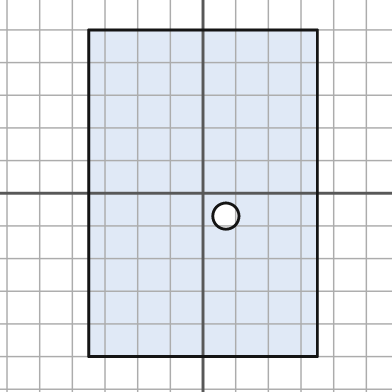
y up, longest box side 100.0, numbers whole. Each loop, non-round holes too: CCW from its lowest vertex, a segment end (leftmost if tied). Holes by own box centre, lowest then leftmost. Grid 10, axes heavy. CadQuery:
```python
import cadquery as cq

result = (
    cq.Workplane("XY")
    .moveTo(-35.0, -50.0)
    .lineTo(35.0, -50.0)
    .lineTo(35.0, 50.0)
    .lineTo(-35.0, 50.0)
    .close()
    .moveTo(7.0, -7.0)
    .circle(4.0)
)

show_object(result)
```